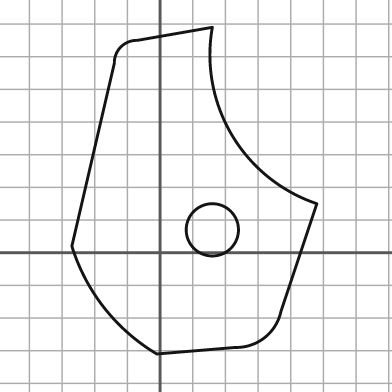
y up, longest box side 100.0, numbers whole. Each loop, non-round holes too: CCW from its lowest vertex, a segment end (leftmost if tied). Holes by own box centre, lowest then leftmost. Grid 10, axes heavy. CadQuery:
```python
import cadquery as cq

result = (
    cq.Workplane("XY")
    .moveTo(-1.0, -31.0)
    .lineTo(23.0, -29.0)
    .threePointArc((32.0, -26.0), (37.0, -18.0))
    .lineTo(48.0, 15.0)
    .threePointArc((22.0, 36.0), (16.0, 69.0))
    .lineTo(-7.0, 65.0)
    .threePointArc((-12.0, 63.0), (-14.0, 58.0))
    .lineTo(-27.0, 2.0)
    .threePointArc((-17.0, -17.0), (-1.0, -31.0))
    .close()
    .moveTo(16.0, 7.0)
    .circle(8.0)
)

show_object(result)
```